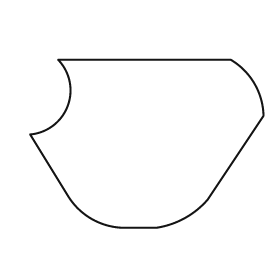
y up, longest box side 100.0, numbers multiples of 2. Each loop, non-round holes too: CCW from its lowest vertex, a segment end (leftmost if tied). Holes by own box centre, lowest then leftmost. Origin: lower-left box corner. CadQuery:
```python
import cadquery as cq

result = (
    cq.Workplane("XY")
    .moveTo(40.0, 0.0)
    .lineTo(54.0, 0.0)
    .threePointArc((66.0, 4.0), (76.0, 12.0))
    .lineTo(100.0, 48.0)
    .threePointArc((96.0, 62.0), (86.0, 72.0))
    .lineTo(12.0, 72.0)
    .threePointArc((16.0, 52.0), (0.0, 40.0))
    .lineTo(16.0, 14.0)
    .threePointArc((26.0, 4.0), (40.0, 0.0))
    .close()
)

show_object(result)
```